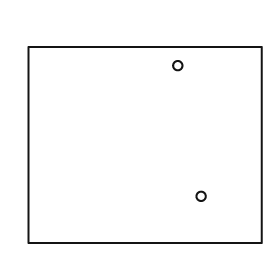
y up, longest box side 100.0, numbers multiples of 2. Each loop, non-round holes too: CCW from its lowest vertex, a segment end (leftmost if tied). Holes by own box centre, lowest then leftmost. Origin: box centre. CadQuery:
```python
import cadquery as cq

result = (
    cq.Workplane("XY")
    .moveTo(-50.0, -42.0)
    .lineTo(50.0, -42.0)
    .lineTo(50.0, 42.0)
    .lineTo(-50.0, 42.0)
    .close()
    .moveTo(24.0, -22.0)
    .circle(2.0)
    .moveTo(14.0, 34.0)
    .circle(2.0)
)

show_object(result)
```